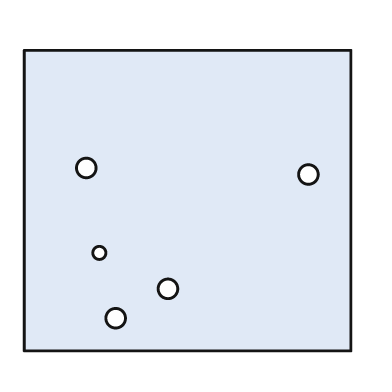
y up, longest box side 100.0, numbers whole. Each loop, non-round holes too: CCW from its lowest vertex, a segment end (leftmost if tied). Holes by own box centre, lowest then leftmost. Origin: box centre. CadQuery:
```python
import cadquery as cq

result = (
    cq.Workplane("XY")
    .moveTo(-50.0, -46.0)
    .lineTo(50.0, -46.0)
    .lineTo(50.0, 46.0)
    .lineTo(-50.0, 46.0)
    .close()
    .moveTo(-22.0, -36.0)
    .circle(3.0)
    .moveTo(-6.0, -27.0)
    .circle(3.0)
    .moveTo(-27.0, -16.0)
    .circle(2.0)
    .moveTo(37.0, 8.0)
    .circle(3.0)
    .moveTo(-31.0, 10.0)
    .circle(3.0)
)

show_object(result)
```